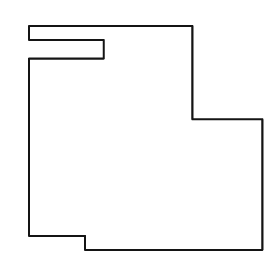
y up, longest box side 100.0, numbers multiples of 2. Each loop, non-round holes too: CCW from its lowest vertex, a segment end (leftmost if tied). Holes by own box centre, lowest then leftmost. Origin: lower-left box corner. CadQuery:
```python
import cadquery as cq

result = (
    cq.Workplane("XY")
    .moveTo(24.0, 0.0)
    .lineTo(100.0, 0.0)
    .lineTo(100.0, 56.0)
    .lineTo(70.0, 56.0)
    .lineTo(70.0, 96.0)
    .lineTo(0.0, 96.0)
    .lineTo(0.0, 90.0)
    .lineTo(32.0, 90.0)
    .lineTo(32.0, 82.0)
    .lineTo(0.0, 82.0)
    .lineTo(0.0, 6.0)
    .lineTo(24.0, 6.0)
    .close()
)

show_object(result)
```